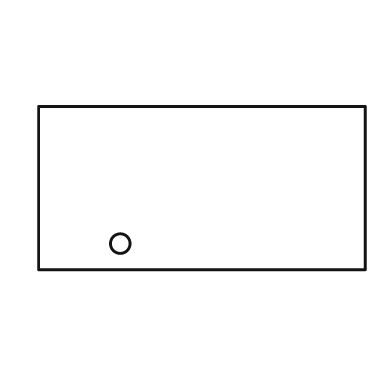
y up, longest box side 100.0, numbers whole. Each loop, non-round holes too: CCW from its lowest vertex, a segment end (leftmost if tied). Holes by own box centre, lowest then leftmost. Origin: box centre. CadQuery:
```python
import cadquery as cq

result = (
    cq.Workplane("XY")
    .moveTo(-50.0, -25.0)
    .lineTo(50.0, -25.0)
    .lineTo(50.0, 25.0)
    .lineTo(-50.0, 25.0)
    .close()
    .moveTo(-25.0, -17.0)
    .circle(3.0)
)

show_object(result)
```